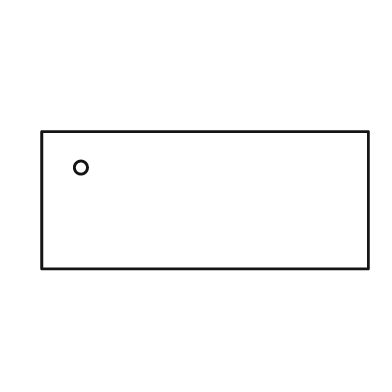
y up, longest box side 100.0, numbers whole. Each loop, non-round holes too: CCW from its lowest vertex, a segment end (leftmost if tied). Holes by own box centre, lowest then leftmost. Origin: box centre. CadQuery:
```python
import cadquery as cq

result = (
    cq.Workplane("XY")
    .moveTo(-50.0, -21.0)
    .lineTo(50.0, -21.0)
    .lineTo(50.0, 21.0)
    .lineTo(-50.0, 21.0)
    .close()
    .moveTo(-38.0, 10.0)
    .circle(2.0)
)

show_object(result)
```